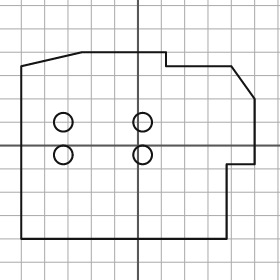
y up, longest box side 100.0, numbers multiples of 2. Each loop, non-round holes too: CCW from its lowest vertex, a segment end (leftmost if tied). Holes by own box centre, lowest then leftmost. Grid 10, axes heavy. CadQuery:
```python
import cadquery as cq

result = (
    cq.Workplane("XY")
    .moveTo(-50.0, -40.0)
    .lineTo(38.0, -40.0)
    .lineTo(38.0, -8.0)
    .lineTo(50.0, -8.0)
    .lineTo(50.0, 20.0)
    .lineTo(40.0, 34.0)
    .lineTo(12.0, 34.0)
    .lineTo(12.0, 40.0)
    .lineTo(-24.0, 40.0)
    .lineTo(-50.0, 34.0)
    .close()
    .moveTo(-32.0, -4.0)
    .circle(4.0)
    .moveTo(2.0, -4.0)
    .circle(4.0)
    .moveTo(-32.0, 10.0)
    .circle(4.0)
    .moveTo(2.0, 10.0)
    .circle(4.0)
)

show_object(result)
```